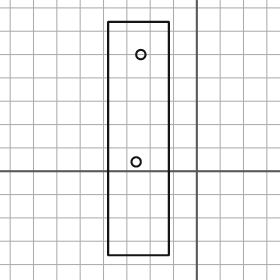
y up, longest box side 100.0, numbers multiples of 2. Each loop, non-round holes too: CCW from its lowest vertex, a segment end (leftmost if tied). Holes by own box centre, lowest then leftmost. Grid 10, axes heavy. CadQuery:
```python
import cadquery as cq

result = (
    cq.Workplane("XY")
    .moveTo(-38.0, -36.0)
    .lineTo(-12.0, -36.0)
    .lineTo(-12.0, 64.0)
    .lineTo(-38.0, 64.0)
    .close()
    .moveTo(-26.0, 4.0)
    .circle(2.0)
    .moveTo(-24.0, 50.0)
    .circle(2.0)
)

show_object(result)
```